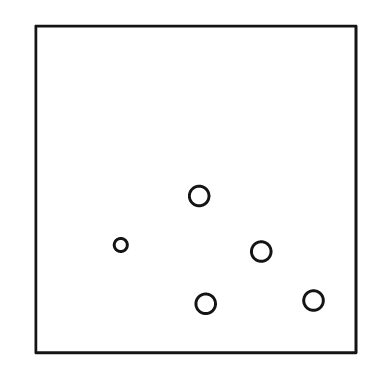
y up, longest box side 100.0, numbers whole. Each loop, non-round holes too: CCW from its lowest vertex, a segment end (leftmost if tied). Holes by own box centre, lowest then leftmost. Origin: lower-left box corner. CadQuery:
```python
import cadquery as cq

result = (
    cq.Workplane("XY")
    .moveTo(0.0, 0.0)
    .lineTo(98.0, 0.0)
    .lineTo(98.0, 100.0)
    .lineTo(0.0, 100.0)
    .close()
    .moveTo(52.0, 15.0)
    .circle(3.0)
    .moveTo(85.0, 16.0)
    .circle(3.0)
    .moveTo(69.0, 31.0)
    .circle(3.0)
    .moveTo(26.0, 33.0)
    .circle(2.0)
    .moveTo(50.0, 48.0)
    .circle(3.0)
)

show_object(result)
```